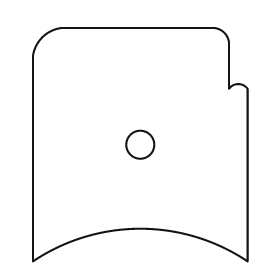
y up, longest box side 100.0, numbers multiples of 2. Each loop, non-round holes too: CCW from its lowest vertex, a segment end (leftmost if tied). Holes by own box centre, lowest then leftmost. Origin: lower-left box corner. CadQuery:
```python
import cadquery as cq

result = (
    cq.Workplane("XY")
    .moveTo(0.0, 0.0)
    .threePointArc((46.0, 14.0), (92.0, 0.0))
    .lineTo(92.0, 74.0)
    .threePointArc((88.0, 76.0), (84.0, 74.0))
    .lineTo(84.0, 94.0)
    .threePointArc((82.0, 98.0), (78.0, 100.0))
    .lineTo(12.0, 100.0)
    .threePointArc((4.0, 96.0), (0.0, 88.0))
    .close()
    .moveTo(46.0, 50.0)
    .circle(6.0)
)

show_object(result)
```